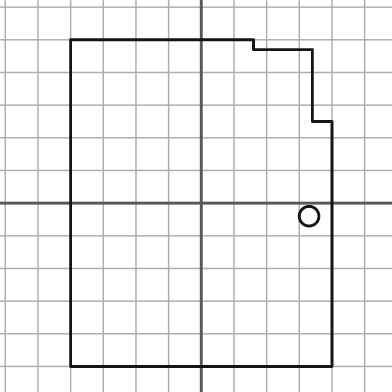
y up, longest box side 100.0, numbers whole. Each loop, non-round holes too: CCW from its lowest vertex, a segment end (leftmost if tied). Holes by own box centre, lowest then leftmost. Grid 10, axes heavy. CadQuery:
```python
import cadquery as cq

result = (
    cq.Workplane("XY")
    .moveTo(-40.0, -50.0)
    .lineTo(40.0, -50.0)
    .lineTo(40.0, 25.0)
    .lineTo(34.0, 25.0)
    .lineTo(34.0, 47.0)
    .lineTo(16.0, 47.0)
    .lineTo(16.0, 50.0)
    .lineTo(-40.0, 50.0)
    .close()
    .moveTo(33.0, -4.0)
    .circle(3.0)
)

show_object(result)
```